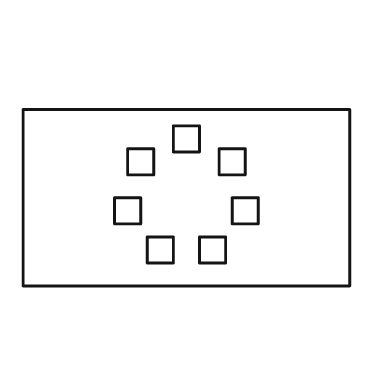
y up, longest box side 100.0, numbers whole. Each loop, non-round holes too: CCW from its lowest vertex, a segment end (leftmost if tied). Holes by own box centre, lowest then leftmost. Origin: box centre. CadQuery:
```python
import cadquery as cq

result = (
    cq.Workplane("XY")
    .moveTo(-50.0, -27.0)
    .lineTo(50.0, -27.0)
    .lineTo(50.0, 27.0)
    .lineTo(-50.0, 27.0)
    .close()
    .moveTo(-12.0, -20.0)
    .lineTo(-4.0, -20.0)
    .lineTo(-4.0, -12.0)
    .lineTo(-12.0, -12.0)
    .close()
    .moveTo(4.0, -20.0)
    .lineTo(12.0, -20.0)
    .lineTo(12.0, -12.0)
    .lineTo(4.0, -12.0)
    .close()
    .moveTo(-22.0, -8.0)
    .lineTo(-14.0, -8.0)
    .lineTo(-14.0, 0.0)
    .lineTo(-22.0, 0.0)
    .close()
    .moveTo(14.0, -8.0)
    .lineTo(22.0, -8.0)
    .lineTo(22.0, 0.0)
    .lineTo(14.0, 0.0)
    .close()
    .moveTo(-18.0, 7.0)
    .lineTo(-10.0, 7.0)
    .lineTo(-10.0, 15.0)
    .lineTo(-18.0, 15.0)
    .close()
    .moveTo(10.0, 7.0)
    .lineTo(18.0, 7.0)
    .lineTo(18.0, 15.0)
    .lineTo(10.0, 15.0)
    .close()
    .moveTo(-4.0, 14.0)
    .lineTo(4.0, 14.0)
    .lineTo(4.0, 22.0)
    .lineTo(-4.0, 22.0)
    .close()
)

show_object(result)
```